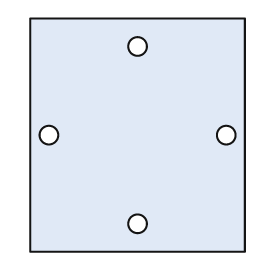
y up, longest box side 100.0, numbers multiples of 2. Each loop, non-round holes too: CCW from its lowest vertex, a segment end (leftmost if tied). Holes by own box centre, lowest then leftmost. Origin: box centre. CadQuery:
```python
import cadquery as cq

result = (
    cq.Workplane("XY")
    .moveTo(-46.0, -50.0)
    .lineTo(46.0, -50.0)
    .lineTo(46.0, 50.0)
    .lineTo(-46.0, 50.0)
    .close()
    .moveTo(0.0, -38.0)
    .circle(4.0)
    .moveTo(-38.0, 0.0)
    .circle(4.0)
    .moveTo(38.0, 0.0)
    .circle(4.0)
    .moveTo(0.0, 38.0)
    .circle(4.0)
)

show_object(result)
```